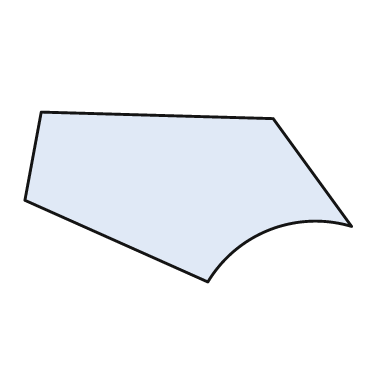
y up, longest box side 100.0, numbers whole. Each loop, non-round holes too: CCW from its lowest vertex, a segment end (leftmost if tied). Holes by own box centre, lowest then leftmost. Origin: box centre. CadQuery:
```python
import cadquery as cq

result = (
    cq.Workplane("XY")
    .moveTo(6.0, -26.0)
    .threePointArc((25.0, -10.0), (50.0, -9.0))
    .lineTo(26.0, 24.0)
    .lineTo(-45.0, 26.0)
    .lineTo(-50.0, -1.0)
    .close()
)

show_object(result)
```